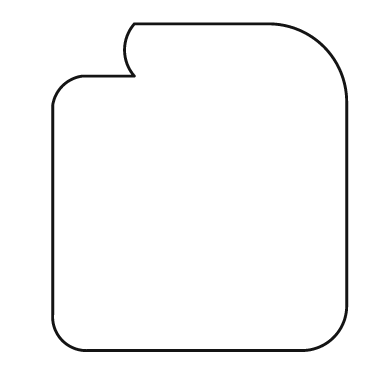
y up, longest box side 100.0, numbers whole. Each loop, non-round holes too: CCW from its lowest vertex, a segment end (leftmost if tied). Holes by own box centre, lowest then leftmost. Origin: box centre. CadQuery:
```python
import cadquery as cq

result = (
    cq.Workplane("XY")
    .moveTo(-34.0, -50.0)
    .lineTo(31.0, -50.0)
    .threePointArc((41.0, -46.0), (45.0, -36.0))
    .lineTo(45.0, 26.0)
    .threePointArc((38.0, 43.0), (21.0, 50.0))
    .lineTo(-20.0, 50.0)
    .threePointArc((-23.0, 42.0), (-20.0, 34.0))
    .lineTo(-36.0, 34.0)
    .threePointArc((-42.0, 31.0), (-45.0, 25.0))
    .lineTo(-45.0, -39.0)
    .threePointArc((-42.0, -47.0), (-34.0, -50.0))
    .close()
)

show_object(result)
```